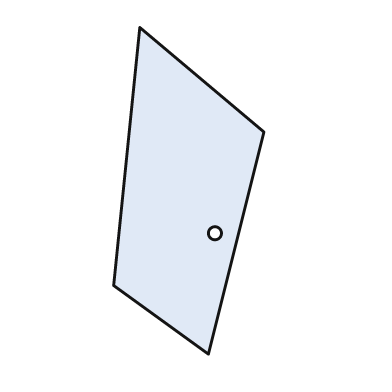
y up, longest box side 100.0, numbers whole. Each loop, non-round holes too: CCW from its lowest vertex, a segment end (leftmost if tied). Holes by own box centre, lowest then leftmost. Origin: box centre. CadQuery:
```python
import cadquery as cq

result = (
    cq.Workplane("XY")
    .moveTo(6.0, -50.0)
    .lineTo(23.0, 18.0)
    .lineTo(-15.0, 50.0)
    .lineTo(-23.0, -29.0)
    .close()
    .moveTo(8.0, -13.0)
    .circle(2.0)
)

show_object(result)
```